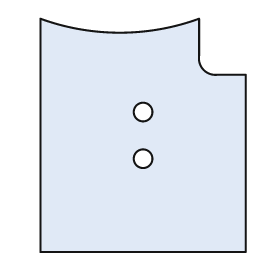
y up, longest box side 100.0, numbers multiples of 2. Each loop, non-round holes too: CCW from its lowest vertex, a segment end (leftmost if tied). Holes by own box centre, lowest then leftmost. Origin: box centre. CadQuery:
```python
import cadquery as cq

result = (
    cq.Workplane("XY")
    .moveTo(-44.0, -50.0)
    .lineTo(44.0, -50.0)
    .lineTo(44.0, 26.0)
    .lineTo(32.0, 26.0)
    .threePointArc((26.0, 28.0), (24.0, 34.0))
    .lineTo(24.0, 50.0)
    .threePointArc((-10.0, 44.0), (-44.0, 50.0))
    .close()
    .moveTo(0.0, -10.0)
    .circle(4.0)
    .moveTo(0.0, 10.0)
    .circle(4.0)
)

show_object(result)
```